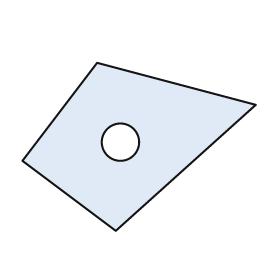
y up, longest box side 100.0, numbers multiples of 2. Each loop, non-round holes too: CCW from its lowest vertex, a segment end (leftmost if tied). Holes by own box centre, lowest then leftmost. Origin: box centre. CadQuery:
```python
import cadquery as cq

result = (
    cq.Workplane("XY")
    .moveTo(-10.0, -36.0)
    .lineTo(50.0, 18.0)
    .lineTo(-18.0, 36.0)
    .lineTo(-50.0, -6.0)
    .close()
    .moveTo(-8.0, 2.0)
    .circle(8.0)
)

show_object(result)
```